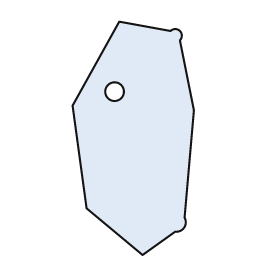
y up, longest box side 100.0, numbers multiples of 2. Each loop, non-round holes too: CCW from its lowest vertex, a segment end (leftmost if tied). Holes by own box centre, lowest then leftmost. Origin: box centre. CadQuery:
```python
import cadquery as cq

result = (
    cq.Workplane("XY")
    .moveTo(4.0, -50.0)
    .lineTo(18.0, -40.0)
    .threePointArc((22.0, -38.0), (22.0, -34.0))
    .lineTo(26.0, 12.0)
    .lineTo(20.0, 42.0)
    .threePointArc((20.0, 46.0), (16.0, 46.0))
    .lineTo(-6.0, 50.0)
    .lineTo(-26.0, 14.0)
    .lineTo(-20.0, -30.0)
    .close()
    .moveTo(-8.0, 20.0)
    .circle(4.0)
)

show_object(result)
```